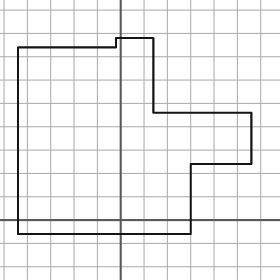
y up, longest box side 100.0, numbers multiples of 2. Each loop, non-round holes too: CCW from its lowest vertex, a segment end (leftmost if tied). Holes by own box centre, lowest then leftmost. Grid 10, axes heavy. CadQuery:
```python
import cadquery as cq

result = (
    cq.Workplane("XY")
    .moveTo(-44.0, -6.0)
    .lineTo(30.0, -6.0)
    .lineTo(30.0, 24.0)
    .lineTo(56.0, 24.0)
    .lineTo(56.0, 46.0)
    .lineTo(14.0, 46.0)
    .lineTo(14.0, 78.0)
    .lineTo(-2.0, 78.0)
    .lineTo(-2.0, 74.0)
    .lineTo(-44.0, 74.0)
    .close()
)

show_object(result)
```